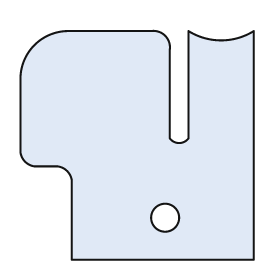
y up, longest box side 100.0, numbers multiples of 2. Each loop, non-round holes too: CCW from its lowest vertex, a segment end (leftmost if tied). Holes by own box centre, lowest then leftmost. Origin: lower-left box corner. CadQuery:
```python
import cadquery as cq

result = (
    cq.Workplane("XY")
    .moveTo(22.0, 0.0)
    .lineTo(100.0, 0.0)
    .lineTo(100.0, 98.0)
    .threePointArc((86.0, 94.0), (72.0, 98.0))
    .lineTo(72.0, 52.0)
    .threePointArc((68.0, 50.0), (64.0, 52.0))
    .lineTo(64.0, 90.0)
    .threePointArc((62.0, 96.0), (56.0, 98.0))
    .lineTo(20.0, 98.0)
    .threePointArc((6.0, 92.0), (0.0, 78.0))
    .lineTo(0.0, 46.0)
    .threePointArc((2.0, 42.0), (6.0, 40.0))
    .lineTo(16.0, 40.0)
    .threePointArc((20.0, 38.0), (22.0, 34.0))
    .close()
    .moveTo(62.0, 18.0)
    .circle(6.0)
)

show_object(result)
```